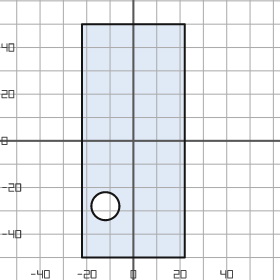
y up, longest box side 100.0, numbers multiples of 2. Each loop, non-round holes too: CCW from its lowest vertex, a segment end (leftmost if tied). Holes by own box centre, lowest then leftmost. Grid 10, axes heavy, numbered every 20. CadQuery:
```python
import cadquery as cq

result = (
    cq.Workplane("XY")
    .moveTo(-22.0, -50.0)
    .lineTo(22.0, -50.0)
    .lineTo(22.0, 50.0)
    .lineTo(-22.0, 50.0)
    .close()
    .moveTo(-12.0, -28.0)
    .circle(6.0)
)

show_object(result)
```